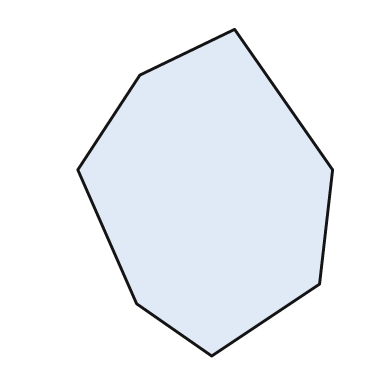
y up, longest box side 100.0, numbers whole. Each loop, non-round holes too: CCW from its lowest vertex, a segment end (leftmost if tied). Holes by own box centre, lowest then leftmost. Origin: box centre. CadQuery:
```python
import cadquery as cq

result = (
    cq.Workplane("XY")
    .moveTo(2.0, -50.0)
    .lineTo(35.0, -28.0)
    .lineTo(39.0, 7.0)
    .lineTo(9.0, 50.0)
    .lineTo(-20.0, 36.0)
    .lineTo(-39.0, 7.0)
    .lineTo(-21.0, -34.0)
    .close()
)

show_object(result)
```